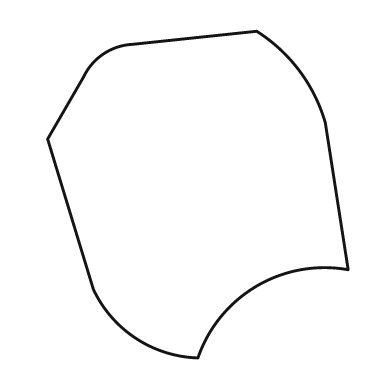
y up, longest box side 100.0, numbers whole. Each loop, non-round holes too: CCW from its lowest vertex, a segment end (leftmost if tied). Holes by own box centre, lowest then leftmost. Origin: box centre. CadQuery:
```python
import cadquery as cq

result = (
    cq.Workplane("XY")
    .moveTo(0.0, -50.0)
    .threePointArc((18.0, -28.0), (46.0, -23.0))
    .lineTo(39.0, 22.0)
    .threePointArc((31.0, 38.0), (18.0, 50.0))
    .lineTo(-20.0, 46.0)
    .threePointArc((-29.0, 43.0), (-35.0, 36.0))
    .lineTo(-46.0, 17.0)
    .lineTo(-32.0, -29.0)
    .threePointArc((-19.0, -44.0), (0.0, -50.0))
    .close()
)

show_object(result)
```